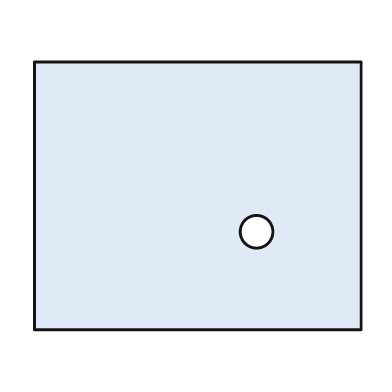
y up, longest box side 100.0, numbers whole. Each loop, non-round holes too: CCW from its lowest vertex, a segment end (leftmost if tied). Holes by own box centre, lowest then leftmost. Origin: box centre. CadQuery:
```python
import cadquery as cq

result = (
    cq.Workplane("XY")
    .moveTo(-50.0, -41.0)
    .lineTo(50.0, -41.0)
    .lineTo(50.0, 41.0)
    .lineTo(-50.0, 41.0)
    .close()
    .moveTo(18.0, -11.0)
    .circle(5.0)
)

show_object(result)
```